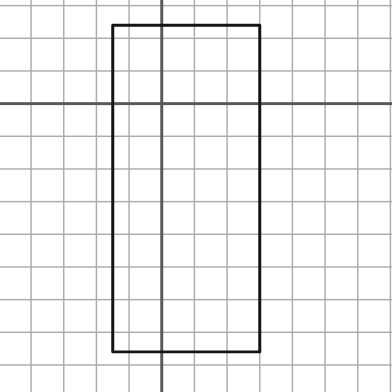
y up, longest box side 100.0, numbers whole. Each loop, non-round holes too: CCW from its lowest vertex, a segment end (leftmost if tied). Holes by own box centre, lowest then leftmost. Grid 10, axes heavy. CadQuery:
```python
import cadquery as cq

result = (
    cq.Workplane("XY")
    .moveTo(-15.0, -76.0)
    .lineTo(30.0, -76.0)
    .lineTo(30.0, 24.0)
    .lineTo(-15.0, 24.0)
    .close()
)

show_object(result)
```